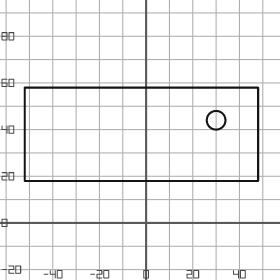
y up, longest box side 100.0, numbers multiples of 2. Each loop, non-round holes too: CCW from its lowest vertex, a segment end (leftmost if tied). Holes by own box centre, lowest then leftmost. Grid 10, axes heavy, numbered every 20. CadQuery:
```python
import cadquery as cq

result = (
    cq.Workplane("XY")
    .moveTo(-52.0, 18.0)
    .lineTo(48.0, 18.0)
    .lineTo(48.0, 58.0)
    .lineTo(-52.0, 58.0)
    .close()
    .moveTo(30.0, 44.0)
    .circle(4.0)
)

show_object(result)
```